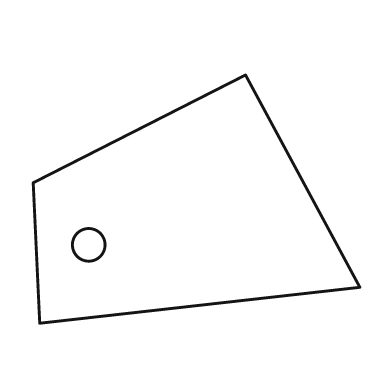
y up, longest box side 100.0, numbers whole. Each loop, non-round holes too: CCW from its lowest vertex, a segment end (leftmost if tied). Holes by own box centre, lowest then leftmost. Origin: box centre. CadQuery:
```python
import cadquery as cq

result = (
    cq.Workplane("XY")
    .moveTo(-48.0, -38.0)
    .lineTo(50.0, -27.0)
    .lineTo(15.0, 38.0)
    .lineTo(-50.0, 5.0)
    .close()
    .moveTo(-33.0, -14.0)
    .circle(5.0)
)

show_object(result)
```